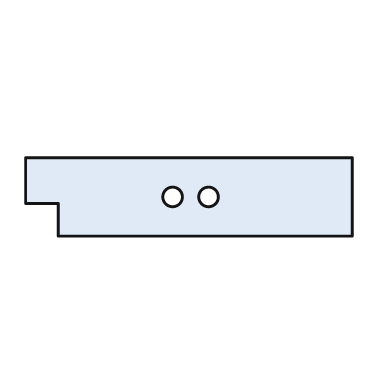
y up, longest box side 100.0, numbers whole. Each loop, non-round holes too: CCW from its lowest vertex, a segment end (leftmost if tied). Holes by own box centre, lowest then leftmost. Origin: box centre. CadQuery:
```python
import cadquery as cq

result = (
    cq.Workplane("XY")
    .moveTo(-40.0, -12.0)
    .lineTo(50.0, -12.0)
    .lineTo(50.0, 12.0)
    .lineTo(-50.0, 12.0)
    .lineTo(-50.0, -2.0)
    .lineTo(-40.0, -2.0)
    .close()
    .moveTo(-5.0, 0.0)
    .circle(3.0)
    .moveTo(6.0, 0.0)
    .circle(3.0)
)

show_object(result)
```